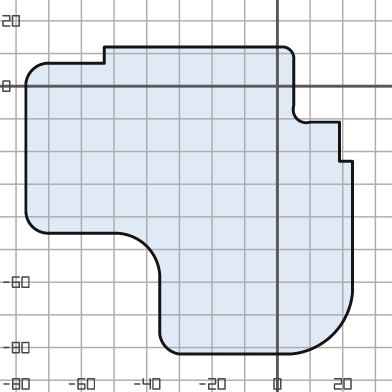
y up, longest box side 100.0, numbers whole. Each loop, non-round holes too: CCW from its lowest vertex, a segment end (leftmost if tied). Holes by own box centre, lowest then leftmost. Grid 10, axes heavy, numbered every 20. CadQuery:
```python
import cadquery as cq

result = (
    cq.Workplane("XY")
    .moveTo(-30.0, -82.0)
    .lineTo(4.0, -82.0)
    .threePointArc((17.0, -76.0), (23.0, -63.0))
    .lineTo(23.0, -23.0)
    .lineTo(19.0, -23.0)
    .lineTo(19.0, -11.0)
    .lineTo(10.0, -11.0)
    .threePointArc((6.0, -10.0), (5.0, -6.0))
    .lineTo(5.0, 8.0)
    .threePointArc((4.0, 11.0), (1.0, 12.0))
    .lineTo(-53.0, 12.0)
    .lineTo(-53.0, 7.0)
    .lineTo(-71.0, 7.0)
    .threePointArc((-75.0, 5.0), (-77.0, 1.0))
    .lineTo(-77.0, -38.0)
    .threePointArc((-75.0, -43.0), (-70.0, -45.0))
    .lineTo(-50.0, -45.0)
    .threePointArc((-40.0, -49.0), (-36.0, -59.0))
    .lineTo(-36.0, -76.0)
    .threePointArc((-34.0, -80.0), (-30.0, -82.0))
    .close()
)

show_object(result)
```